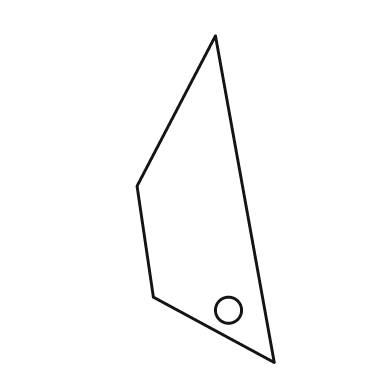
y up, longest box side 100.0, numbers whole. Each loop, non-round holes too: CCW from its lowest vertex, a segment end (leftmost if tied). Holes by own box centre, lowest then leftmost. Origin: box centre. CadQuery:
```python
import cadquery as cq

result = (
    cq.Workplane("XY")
    .moveTo(21.0, -50.0)
    .lineTo(3.0, 50.0)
    .lineTo(-21.0, 4.0)
    .lineTo(-16.0, -30.0)
    .close()
    .moveTo(7.0, -34.0)
    .circle(4.0)
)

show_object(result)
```